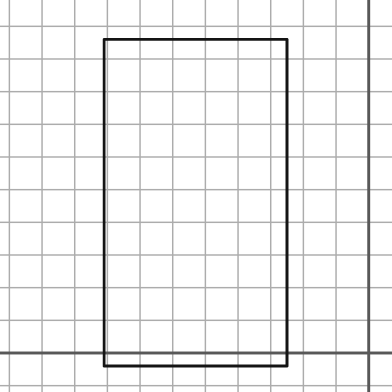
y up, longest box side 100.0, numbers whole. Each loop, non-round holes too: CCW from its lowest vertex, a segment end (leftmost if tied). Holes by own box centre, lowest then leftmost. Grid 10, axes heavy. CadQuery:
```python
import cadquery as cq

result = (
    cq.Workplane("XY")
    .moveTo(-81.0, -4.0)
    .lineTo(-25.0, -4.0)
    .lineTo(-25.0, 96.0)
    .lineTo(-81.0, 96.0)
    .close()
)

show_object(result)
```